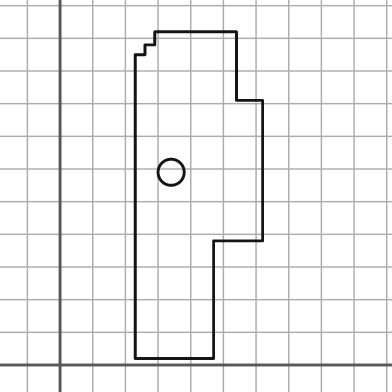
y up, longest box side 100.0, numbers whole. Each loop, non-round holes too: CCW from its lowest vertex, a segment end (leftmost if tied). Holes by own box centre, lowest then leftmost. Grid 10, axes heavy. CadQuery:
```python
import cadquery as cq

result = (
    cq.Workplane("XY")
    .moveTo(23.0, 2.0)
    .lineTo(47.0, 2.0)
    .lineTo(47.0, 38.0)
    .lineTo(62.0, 38.0)
    .lineTo(62.0, 81.0)
    .lineTo(54.0, 81.0)
    .lineTo(54.0, 102.0)
    .lineTo(29.0, 102.0)
    .lineTo(29.0, 98.0)
    .lineTo(26.0, 98.0)
    .lineTo(26.0, 95.0)
    .lineTo(23.0, 95.0)
    .close()
    .moveTo(34.0, 59.0)
    .circle(4.0)
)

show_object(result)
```